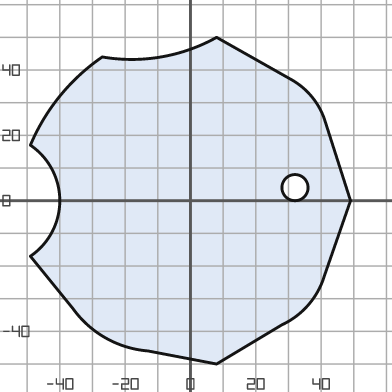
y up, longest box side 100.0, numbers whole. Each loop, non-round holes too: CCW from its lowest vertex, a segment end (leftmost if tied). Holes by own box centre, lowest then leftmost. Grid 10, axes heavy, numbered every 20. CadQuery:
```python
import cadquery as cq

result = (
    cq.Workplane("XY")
    .moveTo(8.0, -50.0)
    .lineTo(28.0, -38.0)
    .threePointArc((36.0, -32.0), (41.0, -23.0))
    .lineTo(49.0, 0.0)
    .lineTo(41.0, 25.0)
    .threePointArc((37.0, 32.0), (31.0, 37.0))
    .lineTo(8.0, 50.0)
    .threePointArc((-9.0, 44.0), (-27.0, 44.0))
    .threePointArc((-40.0, 32.0), (-49.0, 17.0))
    .threePointArc((-40.0, 0.0), (-49.0, -17.0))
    .lineTo(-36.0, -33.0)
    .threePointArc((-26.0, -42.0), (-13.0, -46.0))
    .close()
    .moveTo(32.0, 4.0)
    .circle(4.0)
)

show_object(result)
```